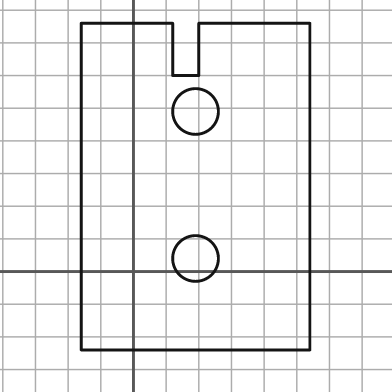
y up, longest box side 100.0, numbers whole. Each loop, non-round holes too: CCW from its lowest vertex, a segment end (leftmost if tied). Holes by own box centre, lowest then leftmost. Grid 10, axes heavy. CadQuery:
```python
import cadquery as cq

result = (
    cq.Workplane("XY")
    .moveTo(-16.0, -24.0)
    .lineTo(54.0, -24.0)
    .lineTo(54.0, 76.0)
    .lineTo(20.0, 76.0)
    .lineTo(20.0, 60.0)
    .lineTo(12.0, 60.0)
    .lineTo(12.0, 76.0)
    .lineTo(-16.0, 76.0)
    .close()
    .moveTo(19.0, 4.0)
    .circle(7.0)
    .moveTo(19.0, 49.0)
    .circle(7.0)
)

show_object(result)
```